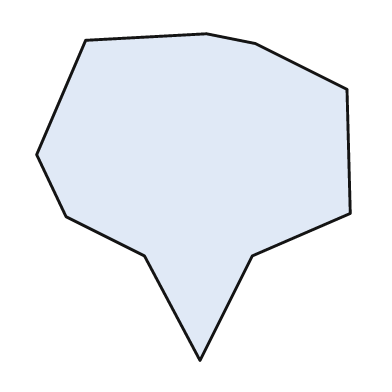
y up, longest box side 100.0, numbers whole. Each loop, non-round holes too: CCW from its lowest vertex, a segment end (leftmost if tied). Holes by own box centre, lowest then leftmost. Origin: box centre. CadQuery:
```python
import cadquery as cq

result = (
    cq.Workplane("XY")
    .moveTo(2.0, -50.0)
    .lineTo(18.0, -18.0)
    .lineTo(48.0, -5.0)
    .lineTo(47.0, 33.0)
    .lineTo(19.0, 47.0)
    .lineTo(4.0, 50.0)
    .lineTo(-33.0, 48.0)
    .lineTo(-48.0, 13.0)
    .lineTo(-39.0, -6.0)
    .lineTo(-15.0, -18.0)
    .close()
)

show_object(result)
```